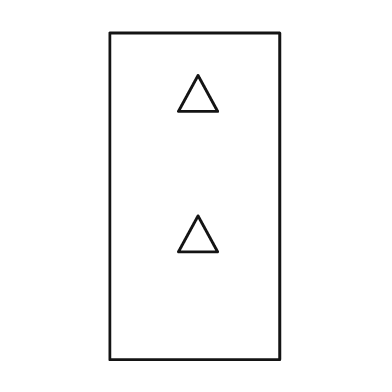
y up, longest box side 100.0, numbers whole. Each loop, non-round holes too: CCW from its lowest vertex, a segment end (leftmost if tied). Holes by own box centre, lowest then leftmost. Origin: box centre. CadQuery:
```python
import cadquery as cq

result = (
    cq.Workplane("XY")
    .moveTo(-26.0, -50.0)
    .lineTo(26.0, -50.0)
    .lineTo(26.0, 50.0)
    .lineTo(-26.0, 50.0)
    .close()
    .moveTo(-5.0, -17.0)
    .lineTo(7.0, -17.0)
    .lineTo(1.0, -6.0)
    .close()
    .moveTo(-5.0, 26.0)
    .lineTo(7.0, 26.0)
    .lineTo(1.0, 37.0)
    .close()
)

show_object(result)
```